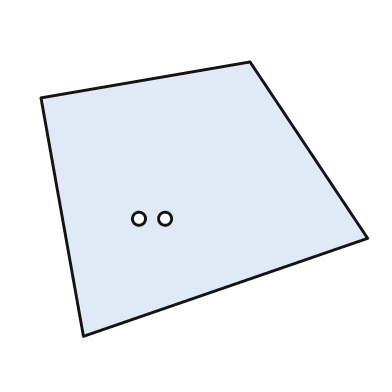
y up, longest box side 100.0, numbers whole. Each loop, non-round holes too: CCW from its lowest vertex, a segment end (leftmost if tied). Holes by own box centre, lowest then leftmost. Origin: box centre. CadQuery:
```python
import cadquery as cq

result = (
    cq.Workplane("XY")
    .moveTo(-37.0, -42.0)
    .lineTo(50.0, -12.0)
    .lineTo(14.0, 42.0)
    .lineTo(-50.0, 31.0)
    .close()
    .moveTo(-20.0, -6.0)
    .circle(2.0)
    .moveTo(-12.0, -6.0)
    .circle(2.0)
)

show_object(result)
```